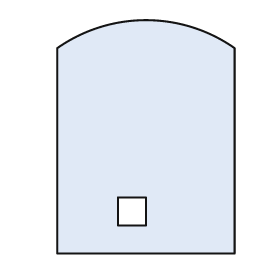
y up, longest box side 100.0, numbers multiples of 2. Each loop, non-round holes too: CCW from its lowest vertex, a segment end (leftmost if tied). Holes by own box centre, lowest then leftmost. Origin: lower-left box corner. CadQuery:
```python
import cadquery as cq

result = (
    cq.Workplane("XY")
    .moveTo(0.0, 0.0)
    .lineTo(76.0, 0.0)
    .lineTo(76.0, 88.0)
    .threePointArc((38.0, 100.0), (0.0, 88.0))
    .close()
    .moveTo(26.0, 12.0)
    .lineTo(38.0, 12.0)
    .lineTo(38.0, 24.0)
    .lineTo(26.0, 24.0)
    .close()
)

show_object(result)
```